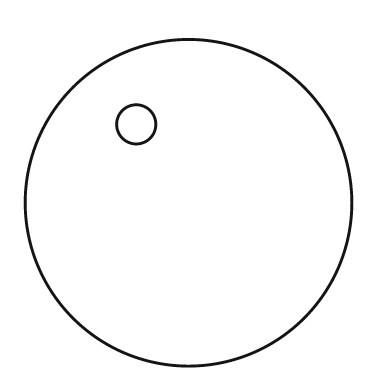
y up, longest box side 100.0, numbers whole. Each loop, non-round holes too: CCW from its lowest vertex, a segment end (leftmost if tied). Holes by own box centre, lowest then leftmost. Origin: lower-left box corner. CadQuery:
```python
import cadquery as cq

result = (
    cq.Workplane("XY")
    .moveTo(50.0, 50.0)
    .circle(50.0)
    .moveTo(34.0, 74.0)
    .circle(6.0)
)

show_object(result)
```